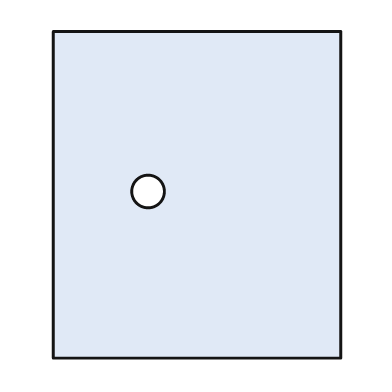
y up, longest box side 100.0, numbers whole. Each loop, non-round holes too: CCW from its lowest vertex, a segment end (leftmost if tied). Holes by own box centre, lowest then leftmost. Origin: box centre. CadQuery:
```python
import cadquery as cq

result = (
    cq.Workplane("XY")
    .moveTo(-44.0, -50.0)
    .lineTo(44.0, -50.0)
    .lineTo(44.0, 50.0)
    .lineTo(-44.0, 50.0)
    .close()
    .moveTo(-15.0, 1.0)
    .circle(5.0)
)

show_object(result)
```